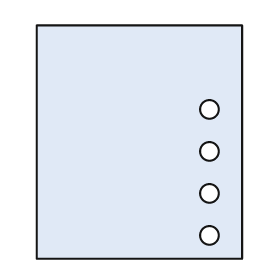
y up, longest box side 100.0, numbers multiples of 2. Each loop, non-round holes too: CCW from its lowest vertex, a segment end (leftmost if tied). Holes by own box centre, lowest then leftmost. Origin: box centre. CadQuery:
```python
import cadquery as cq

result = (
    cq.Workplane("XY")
    .moveTo(-44.0, -50.0)
    .lineTo(44.0, -50.0)
    .lineTo(44.0, 50.0)
    .lineTo(-44.0, 50.0)
    .close()
    .moveTo(30.0, -40.0)
    .circle(4.0)
    .moveTo(30.0, -22.0)
    .circle(4.0)
    .moveTo(30.0, -4.0)
    .circle(4.0)
    .moveTo(30.0, 14.0)
    .circle(4.0)
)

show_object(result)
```